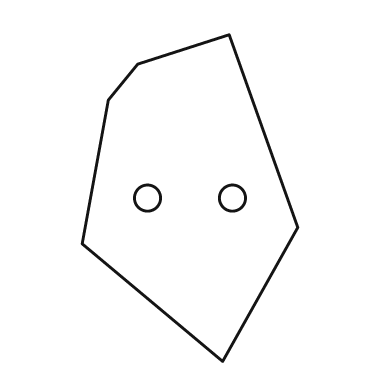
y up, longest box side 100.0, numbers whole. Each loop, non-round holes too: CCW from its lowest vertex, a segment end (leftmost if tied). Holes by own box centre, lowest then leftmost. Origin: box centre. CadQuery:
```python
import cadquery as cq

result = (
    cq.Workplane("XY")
    .moveTo(10.0, -50.0)
    .lineTo(33.0, -9.0)
    .lineTo(12.0, 50.0)
    .lineTo(-16.0, 41.0)
    .lineTo(-25.0, 30.0)
    .lineTo(-33.0, -14.0)
    .close()
    .moveTo(-13.0, 0.0)
    .circle(4.0)
    .moveTo(13.0, 0.0)
    .circle(4.0)
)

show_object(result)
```